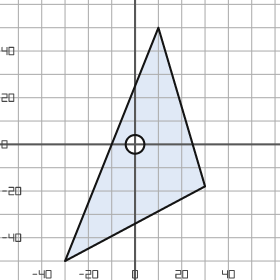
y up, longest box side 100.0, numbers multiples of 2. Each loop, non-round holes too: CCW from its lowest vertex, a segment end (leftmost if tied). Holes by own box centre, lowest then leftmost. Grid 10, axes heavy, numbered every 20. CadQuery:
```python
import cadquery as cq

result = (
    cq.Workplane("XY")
    .moveTo(-30.0, -50.0)
    .lineTo(30.0, -18.0)
    .lineTo(10.0, 50.0)
    .close()
    .moveTo(0.0, 0.0)
    .circle(4.0)
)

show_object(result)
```